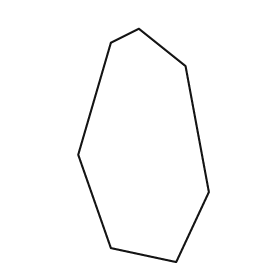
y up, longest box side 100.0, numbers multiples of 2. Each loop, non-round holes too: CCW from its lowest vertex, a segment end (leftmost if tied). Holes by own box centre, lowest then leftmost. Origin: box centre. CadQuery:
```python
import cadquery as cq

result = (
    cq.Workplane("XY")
    .moveTo(14.0, -50.0)
    .lineTo(28.0, -20.0)
    .lineTo(18.0, 34.0)
    .lineTo(-2.0, 50.0)
    .lineTo(-14.0, 44.0)
    .lineTo(-28.0, -4.0)
    .lineTo(-14.0, -44.0)
    .close()
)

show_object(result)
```